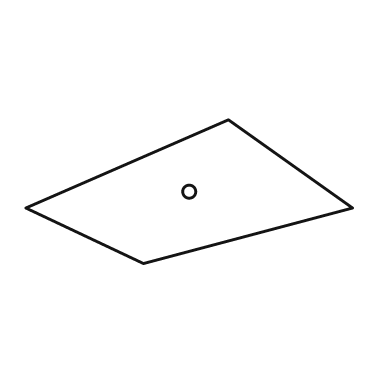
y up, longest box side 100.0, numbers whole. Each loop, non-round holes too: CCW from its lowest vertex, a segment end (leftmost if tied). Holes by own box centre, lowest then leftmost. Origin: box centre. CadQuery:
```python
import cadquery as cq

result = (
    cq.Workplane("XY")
    .moveTo(-14.0, -22.0)
    .lineTo(50.0, -5.0)
    .lineTo(12.0, 22.0)
    .lineTo(-50.0, -5.0)
    .close()
    .moveTo(0.0, 0.0)
    .circle(2.0)
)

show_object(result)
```